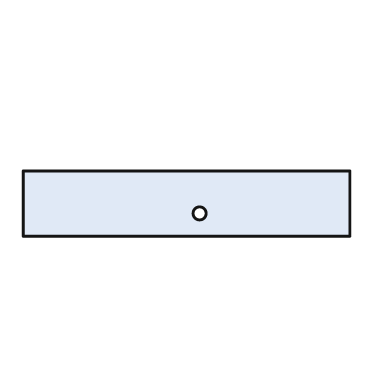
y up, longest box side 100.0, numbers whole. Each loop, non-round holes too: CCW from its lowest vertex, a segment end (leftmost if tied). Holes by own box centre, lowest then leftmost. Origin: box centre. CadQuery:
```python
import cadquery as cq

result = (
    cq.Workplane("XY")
    .moveTo(-50.0, -10.0)
    .lineTo(50.0, -10.0)
    .lineTo(50.0, 10.0)
    .lineTo(-50.0, 10.0)
    .close()
    .moveTo(4.0, -3.0)
    .circle(2.0)
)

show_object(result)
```